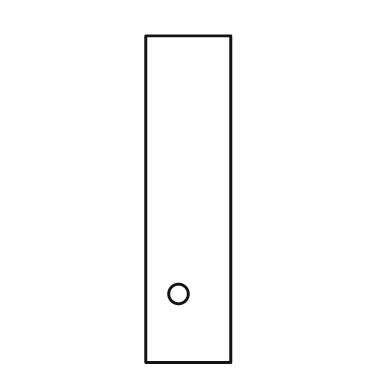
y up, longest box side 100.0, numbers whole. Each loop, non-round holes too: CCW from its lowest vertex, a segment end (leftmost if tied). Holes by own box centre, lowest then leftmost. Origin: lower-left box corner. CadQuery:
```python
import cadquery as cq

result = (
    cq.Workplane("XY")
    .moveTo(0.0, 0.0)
    .lineTo(26.0, 0.0)
    .lineTo(26.0, 100.0)
    .lineTo(0.0, 100.0)
    .close()
    .moveTo(10.0, 21.0)
    .circle(3.0)
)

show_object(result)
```